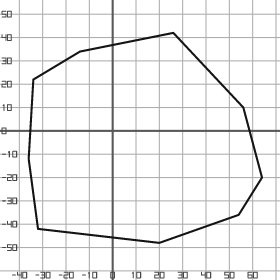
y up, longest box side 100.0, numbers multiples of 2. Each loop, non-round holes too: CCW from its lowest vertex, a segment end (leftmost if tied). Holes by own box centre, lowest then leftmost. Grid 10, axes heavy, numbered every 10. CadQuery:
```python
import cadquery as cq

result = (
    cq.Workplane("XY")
    .moveTo(20.0, -48.0)
    .lineTo(54.0, -36.0)
    .lineTo(64.0, -20.0)
    .lineTo(56.0, 10.0)
    .lineTo(26.0, 42.0)
    .lineTo(-14.0, 34.0)
    .lineTo(-34.0, 22.0)
    .lineTo(-36.0, -12.0)
    .lineTo(-32.0, -42.0)
    .close()
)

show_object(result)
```